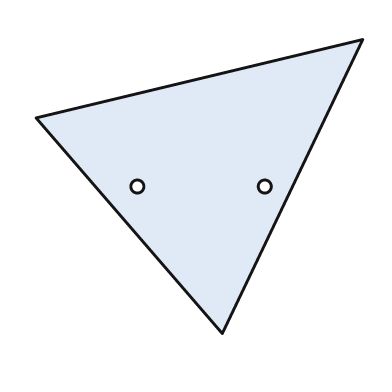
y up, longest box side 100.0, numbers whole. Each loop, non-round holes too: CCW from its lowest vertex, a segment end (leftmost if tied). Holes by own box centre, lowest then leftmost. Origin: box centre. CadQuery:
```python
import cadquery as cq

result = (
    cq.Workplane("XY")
    .moveTo(7.0, -45.0)
    .lineTo(50.0, 45.0)
    .lineTo(-50.0, 21.0)
    .close()
    .moveTo(-19.0, 0.0)
    .circle(2.0)
    .moveTo(20.0, 0.0)
    .circle(2.0)
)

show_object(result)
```